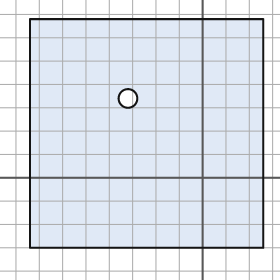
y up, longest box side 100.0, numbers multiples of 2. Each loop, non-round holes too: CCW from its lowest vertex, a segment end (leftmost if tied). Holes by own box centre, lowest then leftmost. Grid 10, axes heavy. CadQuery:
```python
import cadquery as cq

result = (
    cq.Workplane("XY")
    .moveTo(-74.0, -30.0)
    .lineTo(26.0, -30.0)
    .lineTo(26.0, 68.0)
    .lineTo(-74.0, 68.0)
    .close()
    .moveTo(-32.0, 34.0)
    .circle(4.0)
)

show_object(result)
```